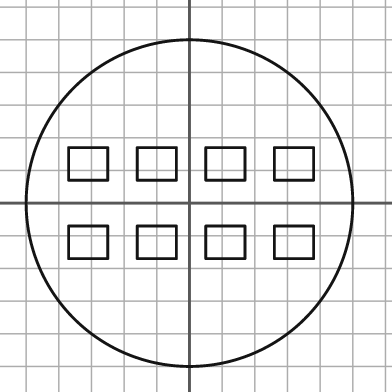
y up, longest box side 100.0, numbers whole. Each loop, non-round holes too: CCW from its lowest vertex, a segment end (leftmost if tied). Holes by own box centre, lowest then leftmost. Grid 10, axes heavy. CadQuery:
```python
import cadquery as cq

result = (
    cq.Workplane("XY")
    .moveTo(0.0, 0.0)
    .circle(50.0)
    .moveTo(-37.0, -17.0)
    .lineTo(-25.0, -17.0)
    .lineTo(-25.0, -7.0)
    .lineTo(-37.0, -7.0)
    .close()
    .moveTo(-16.0, -17.0)
    .lineTo(-4.0, -17.0)
    .lineTo(-4.0, -7.0)
    .lineTo(-16.0, -7.0)
    .close()
    .moveTo(5.0, -17.0)
    .lineTo(17.0, -17.0)
    .lineTo(17.0, -7.0)
    .lineTo(5.0, -7.0)
    .close()
    .moveTo(26.0, -17.0)
    .lineTo(38.0, -17.0)
    .lineTo(38.0, -7.0)
    .lineTo(26.0, -7.0)
    .close()
    .moveTo(-37.0, 7.0)
    .lineTo(-25.0, 7.0)
    .lineTo(-25.0, 17.0)
    .lineTo(-37.0, 17.0)
    .close()
    .moveTo(-16.0, 7.0)
    .lineTo(-4.0, 7.0)
    .lineTo(-4.0, 17.0)
    .lineTo(-16.0, 17.0)
    .close()
    .moveTo(5.0, 7.0)
    .lineTo(17.0, 7.0)
    .lineTo(17.0, 17.0)
    .lineTo(5.0, 17.0)
    .close()
    .moveTo(26.0, 7.0)
    .lineTo(38.0, 7.0)
    .lineTo(38.0, 17.0)
    .lineTo(26.0, 17.0)
    .close()
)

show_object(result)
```